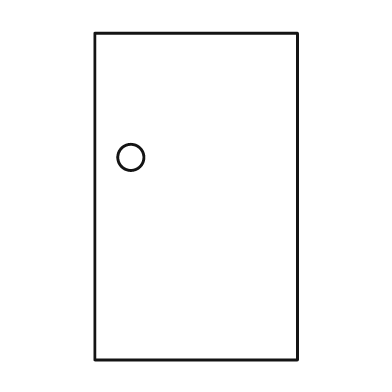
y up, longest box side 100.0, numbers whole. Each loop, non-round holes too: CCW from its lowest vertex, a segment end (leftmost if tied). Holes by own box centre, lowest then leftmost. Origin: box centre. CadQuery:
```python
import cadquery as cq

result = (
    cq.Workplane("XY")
    .moveTo(-31.0, -50.0)
    .lineTo(31.0, -50.0)
    .lineTo(31.0, 50.0)
    .lineTo(-31.0, 50.0)
    .close()
    .moveTo(-20.0, 12.0)
    .circle(4.0)
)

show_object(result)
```